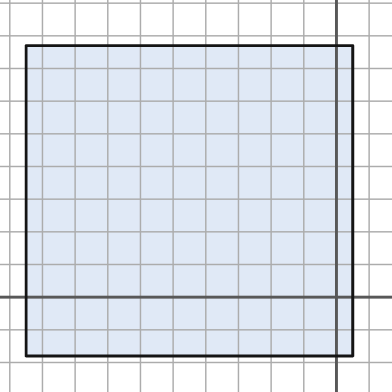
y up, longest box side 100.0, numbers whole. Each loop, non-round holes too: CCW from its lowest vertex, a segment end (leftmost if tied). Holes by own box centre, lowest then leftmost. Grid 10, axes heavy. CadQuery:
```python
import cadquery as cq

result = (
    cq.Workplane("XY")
    .moveTo(-95.0, -18.0)
    .lineTo(5.0, -18.0)
    .lineTo(5.0, 77.0)
    .lineTo(-95.0, 77.0)
    .close()
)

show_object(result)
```